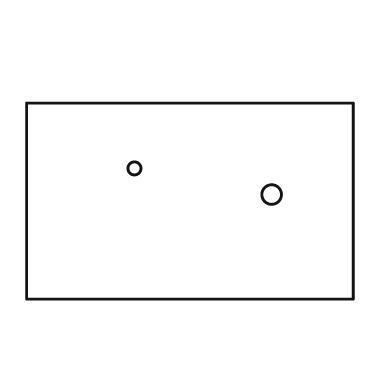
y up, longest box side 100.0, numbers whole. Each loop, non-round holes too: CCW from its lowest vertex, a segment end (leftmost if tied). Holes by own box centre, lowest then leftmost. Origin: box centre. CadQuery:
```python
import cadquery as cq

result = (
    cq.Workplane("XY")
    .moveTo(-50.0, -30.0)
    .lineTo(50.0, -30.0)
    .lineTo(50.0, 30.0)
    .lineTo(-50.0, 30.0)
    .close()
    .moveTo(25.0, 2.0)
    .circle(3.0)
    .moveTo(-17.0, 10.0)
    .circle(2.0)
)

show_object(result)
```